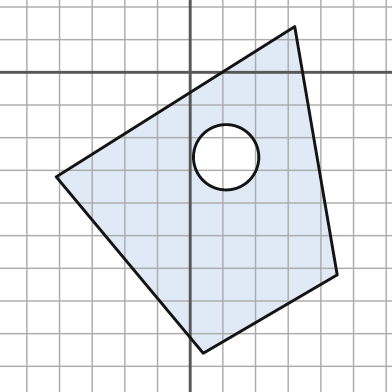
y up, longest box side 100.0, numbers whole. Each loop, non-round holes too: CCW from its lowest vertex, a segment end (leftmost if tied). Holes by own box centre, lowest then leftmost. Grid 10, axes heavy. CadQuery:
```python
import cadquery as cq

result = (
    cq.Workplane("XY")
    .moveTo(4.0, -86.0)
    .lineTo(45.0, -62.0)
    .lineTo(32.0, 14.0)
    .lineTo(-41.0, -32.0)
    .close()
    .moveTo(11.0, -26.0)
    .circle(10.0)
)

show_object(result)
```